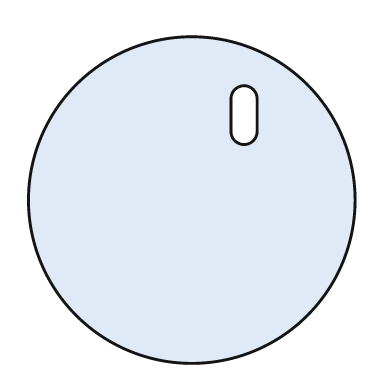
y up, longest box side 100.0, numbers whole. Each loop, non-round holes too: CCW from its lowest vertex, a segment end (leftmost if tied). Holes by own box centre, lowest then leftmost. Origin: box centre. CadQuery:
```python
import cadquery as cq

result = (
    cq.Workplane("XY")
    .moveTo(0.0, 0.0)
    .circle(50.0)
    .moveTo(12.0, 21.0)
    .threePointArc((16.0, 17.0), (20.0, 21.0))
    .lineTo(20.0, 31.0)
    .threePointArc((16.0, 35.0), (12.0, 31.0))
    .close()
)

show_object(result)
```